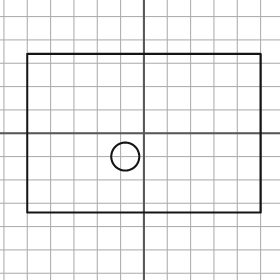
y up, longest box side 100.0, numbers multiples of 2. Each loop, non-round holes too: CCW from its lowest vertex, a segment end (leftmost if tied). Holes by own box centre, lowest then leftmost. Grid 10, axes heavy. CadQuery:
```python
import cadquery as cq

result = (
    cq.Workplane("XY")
    .moveTo(-50.0, -34.0)
    .lineTo(50.0, -34.0)
    .lineTo(50.0, 34.0)
    .lineTo(-50.0, 34.0)
    .close()
    .moveTo(-8.0, -10.0)
    .circle(6.0)
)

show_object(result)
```